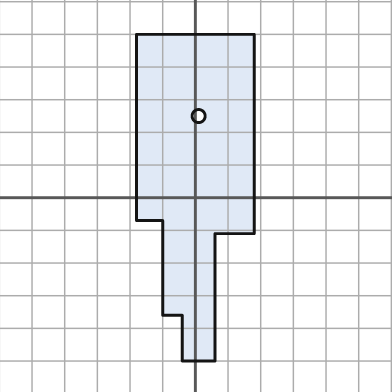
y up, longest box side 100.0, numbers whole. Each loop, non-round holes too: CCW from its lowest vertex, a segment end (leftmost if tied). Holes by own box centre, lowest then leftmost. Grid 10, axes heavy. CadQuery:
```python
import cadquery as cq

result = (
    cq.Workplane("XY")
    .moveTo(-4.0, -50.0)
    .lineTo(6.0, -50.0)
    .lineTo(6.0, -11.0)
    .lineTo(18.0, -11.0)
    .lineTo(18.0, 50.0)
    .lineTo(-18.0, 50.0)
    .lineTo(-18.0, -7.0)
    .lineTo(-10.0, -7.0)
    .lineTo(-10.0, -36.0)
    .lineTo(-4.0, -36.0)
    .close()
    .moveTo(1.0, 25.0)
    .circle(2.0)
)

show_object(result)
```